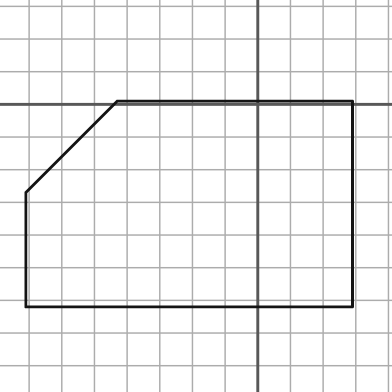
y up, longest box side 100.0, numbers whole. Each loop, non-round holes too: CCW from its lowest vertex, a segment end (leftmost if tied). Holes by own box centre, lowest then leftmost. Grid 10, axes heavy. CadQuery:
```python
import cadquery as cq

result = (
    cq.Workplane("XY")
    .moveTo(-71.0, -62.0)
    .lineTo(29.0, -62.0)
    .lineTo(29.0, 1.0)
    .lineTo(-43.0, 1.0)
    .lineTo(-71.0, -27.0)
    .close()
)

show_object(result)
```